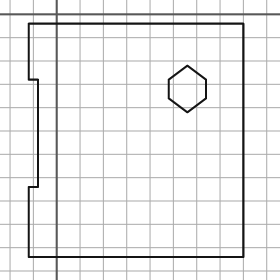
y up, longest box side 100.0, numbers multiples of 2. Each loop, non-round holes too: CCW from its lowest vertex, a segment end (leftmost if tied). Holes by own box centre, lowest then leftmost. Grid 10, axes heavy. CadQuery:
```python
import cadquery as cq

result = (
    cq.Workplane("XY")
    .moveTo(-12.0, -104.0)
    .lineTo(80.0, -104.0)
    .lineTo(80.0, -4.0)
    .lineTo(-12.0, -4.0)
    .lineTo(-12.0, -28.0)
    .lineTo(-8.0, -28.0)
    .lineTo(-8.0, -74.0)
    .lineTo(-12.0, -74.0)
    .close()
    .moveTo(56.0, -42.0)
    .lineTo(64.0, -36.0)
    .lineTo(64.0, -28.0)
    .lineTo(56.0, -22.0)
    .lineTo(48.0, -28.0)
    .lineTo(48.0, -36.0)
    .close()
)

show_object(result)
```